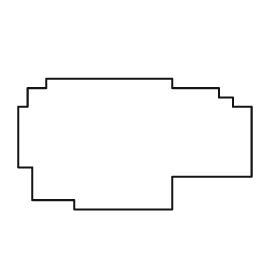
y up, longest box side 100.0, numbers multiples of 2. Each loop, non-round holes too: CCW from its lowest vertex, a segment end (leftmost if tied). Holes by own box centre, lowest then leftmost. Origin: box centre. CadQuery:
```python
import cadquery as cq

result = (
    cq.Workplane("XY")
    .moveTo(-26.0, -28.0)
    .lineTo(16.0, -28.0)
    .lineTo(16.0, -14.0)
    .lineTo(50.0, -14.0)
    .lineTo(50.0, 16.0)
    .lineTo(42.0, 16.0)
    .lineTo(42.0, 20.0)
    .lineTo(36.0, 20.0)
    .lineTo(36.0, 24.0)
    .lineTo(16.0, 24.0)
    .lineTo(16.0, 28.0)
    .lineTo(-38.0, 28.0)
    .lineTo(-38.0, 24.0)
    .lineTo(-46.0, 24.0)
    .lineTo(-46.0, 16.0)
    .lineTo(-50.0, 16.0)
    .lineTo(-50.0, -10.0)
    .lineTo(-44.0, -10.0)
    .lineTo(-44.0, -24.0)
    .lineTo(-26.0, -24.0)
    .close()
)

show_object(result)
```